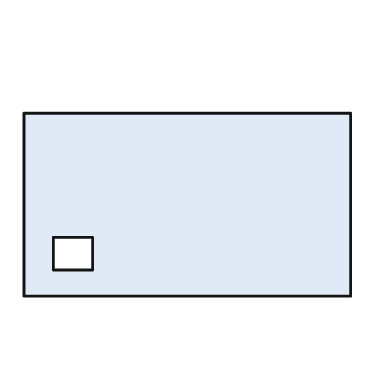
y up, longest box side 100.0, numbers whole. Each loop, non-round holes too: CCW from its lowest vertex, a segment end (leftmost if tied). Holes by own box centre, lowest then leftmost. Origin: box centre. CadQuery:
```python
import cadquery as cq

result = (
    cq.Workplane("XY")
    .moveTo(-50.0, -28.0)
    .lineTo(50.0, -28.0)
    .lineTo(50.0, 28.0)
    .lineTo(-50.0, 28.0)
    .close()
    .moveTo(-41.0, -20.0)
    .lineTo(-29.0, -20.0)
    .lineTo(-29.0, -10.0)
    .lineTo(-41.0, -10.0)
    .close()
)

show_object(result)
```